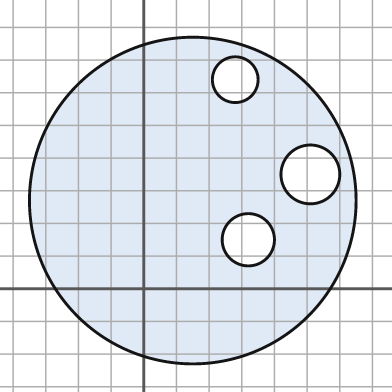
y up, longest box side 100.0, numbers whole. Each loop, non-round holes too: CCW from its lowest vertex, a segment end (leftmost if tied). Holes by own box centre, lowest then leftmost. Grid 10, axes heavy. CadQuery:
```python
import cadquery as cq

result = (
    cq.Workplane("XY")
    .moveTo(15.0, 27.0)
    .circle(50.0)
    .moveTo(32.0, 15.0)
    .circle(8.0)
    .moveTo(51.0, 35.0)
    .circle(9.0)
    .moveTo(28.0, 64.0)
    .circle(7.0)
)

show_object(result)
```